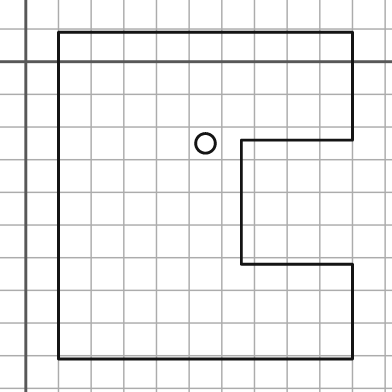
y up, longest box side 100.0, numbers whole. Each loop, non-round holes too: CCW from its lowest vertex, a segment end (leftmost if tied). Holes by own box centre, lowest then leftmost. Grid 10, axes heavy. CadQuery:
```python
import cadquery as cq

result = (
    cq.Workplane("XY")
    .moveTo(10.0, -91.0)
    .lineTo(100.0, -91.0)
    .lineTo(100.0, -62.0)
    .lineTo(66.0, -62.0)
    .lineTo(66.0, -24.0)
    .lineTo(100.0, -24.0)
    .lineTo(100.0, 9.0)
    .lineTo(10.0, 9.0)
    .close()
    .moveTo(55.0, -25.0)
    .circle(3.0)
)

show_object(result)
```